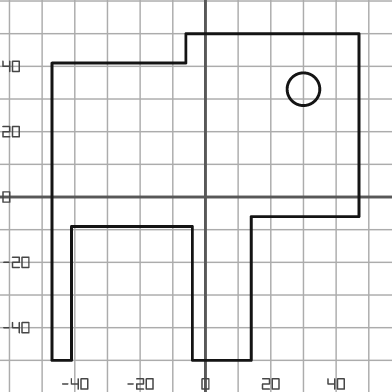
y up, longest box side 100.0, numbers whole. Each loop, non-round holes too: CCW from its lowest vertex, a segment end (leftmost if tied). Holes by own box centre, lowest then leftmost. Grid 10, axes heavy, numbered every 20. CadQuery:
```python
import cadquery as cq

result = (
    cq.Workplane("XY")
    .moveTo(-47.0, -50.0)
    .lineTo(-41.0, -50.0)
    .lineTo(-41.0, -9.0)
    .lineTo(-4.0, -9.0)
    .lineTo(-4.0, -50.0)
    .lineTo(14.0, -50.0)
    .lineTo(14.0, -6.0)
    .lineTo(47.0, -6.0)
    .lineTo(47.0, 50.0)
    .lineTo(-6.0, 50.0)
    .lineTo(-6.0, 41.0)
    .lineTo(-47.0, 41.0)
    .close()
    .moveTo(30.0, 33.0)
    .circle(5.0)
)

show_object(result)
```